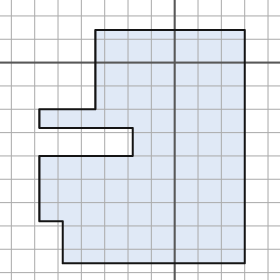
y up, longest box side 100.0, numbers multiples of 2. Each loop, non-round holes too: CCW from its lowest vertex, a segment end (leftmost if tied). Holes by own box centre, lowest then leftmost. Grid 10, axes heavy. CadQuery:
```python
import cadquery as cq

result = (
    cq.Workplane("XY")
    .moveTo(-48.0, -86.0)
    .lineTo(30.0, -86.0)
    .lineTo(30.0, 14.0)
    .lineTo(-34.0, 14.0)
    .lineTo(-34.0, -20.0)
    .lineTo(-58.0, -20.0)
    .lineTo(-58.0, -28.0)
    .lineTo(-18.0, -28.0)
    .lineTo(-18.0, -40.0)
    .lineTo(-58.0, -40.0)
    .lineTo(-58.0, -68.0)
    .lineTo(-48.0, -68.0)
    .close()
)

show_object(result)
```